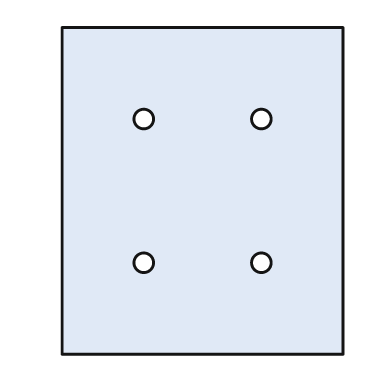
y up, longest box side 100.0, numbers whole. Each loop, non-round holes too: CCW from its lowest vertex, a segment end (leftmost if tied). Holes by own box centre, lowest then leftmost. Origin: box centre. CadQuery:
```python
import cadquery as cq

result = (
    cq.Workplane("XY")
    .moveTo(-43.0, -50.0)
    .lineTo(43.0, -50.0)
    .lineTo(43.0, 50.0)
    .lineTo(-43.0, 50.0)
    .close()
    .moveTo(-18.0, -22.0)
    .circle(3.0)
    .moveTo(18.0, -22.0)
    .circle(3.0)
    .moveTo(-18.0, 22.0)
    .circle(3.0)
    .moveTo(18.0, 22.0)
    .circle(3.0)
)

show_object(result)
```